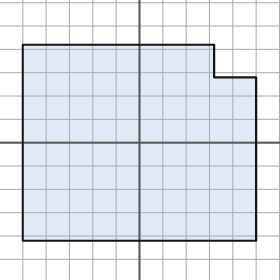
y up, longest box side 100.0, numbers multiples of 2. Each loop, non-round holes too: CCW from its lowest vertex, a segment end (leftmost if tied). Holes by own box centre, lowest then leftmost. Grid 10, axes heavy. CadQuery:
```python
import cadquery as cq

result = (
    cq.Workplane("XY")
    .moveTo(-50.0, -42.0)
    .lineTo(50.0, -42.0)
    .lineTo(50.0, 28.0)
    .lineTo(32.0, 28.0)
    .lineTo(32.0, 42.0)
    .lineTo(-50.0, 42.0)
    .close()
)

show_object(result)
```